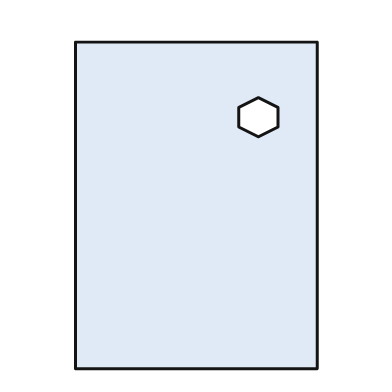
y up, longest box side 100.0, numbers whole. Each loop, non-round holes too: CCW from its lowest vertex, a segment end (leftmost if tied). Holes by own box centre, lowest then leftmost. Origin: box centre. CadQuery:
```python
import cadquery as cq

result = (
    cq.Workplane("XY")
    .moveTo(-37.0, -50.0)
    .lineTo(37.0, -50.0)
    .lineTo(37.0, 50.0)
    .lineTo(-37.0, 50.0)
    .close()
    .moveTo(19.0, 21.0)
    .lineTo(25.0, 24.0)
    .lineTo(25.0, 30.0)
    .lineTo(19.0, 33.0)
    .lineTo(13.0, 30.0)
    .lineTo(13.0, 24.0)
    .close()
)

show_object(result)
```